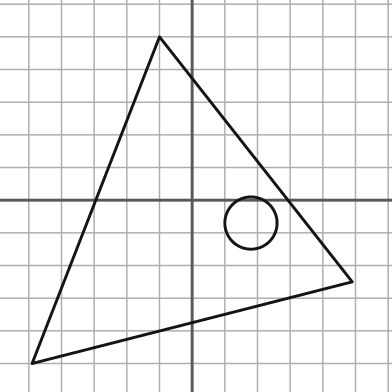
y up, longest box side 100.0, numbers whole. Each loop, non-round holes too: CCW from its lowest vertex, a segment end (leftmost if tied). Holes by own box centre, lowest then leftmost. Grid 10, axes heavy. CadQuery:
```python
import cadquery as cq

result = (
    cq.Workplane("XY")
    .moveTo(-49.0, -50.0)
    .lineTo(49.0, -25.0)
    .lineTo(-10.0, 50.0)
    .close()
    .moveTo(18.0, -7.0)
    .circle(8.0)
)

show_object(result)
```